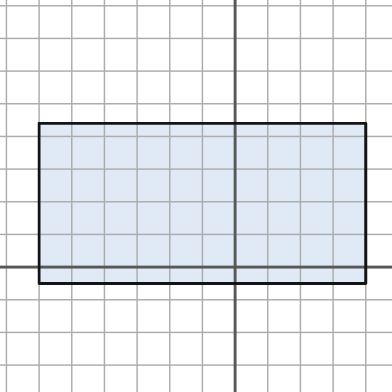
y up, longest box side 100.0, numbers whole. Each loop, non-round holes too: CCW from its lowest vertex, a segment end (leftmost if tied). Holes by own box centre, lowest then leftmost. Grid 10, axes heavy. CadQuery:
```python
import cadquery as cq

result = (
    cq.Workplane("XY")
    .moveTo(-60.0, -5.0)
    .lineTo(40.0, -5.0)
    .lineTo(40.0, 44.0)
    .lineTo(-60.0, 44.0)
    .close()
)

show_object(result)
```